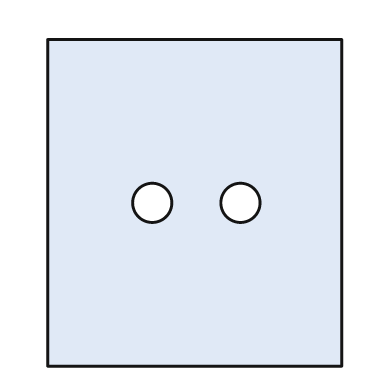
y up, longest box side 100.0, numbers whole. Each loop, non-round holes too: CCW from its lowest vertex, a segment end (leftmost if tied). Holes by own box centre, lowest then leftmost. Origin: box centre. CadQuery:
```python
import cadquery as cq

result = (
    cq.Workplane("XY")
    .moveTo(-45.0, -50.0)
    .lineTo(45.0, -50.0)
    .lineTo(45.0, 50.0)
    .lineTo(-45.0, 50.0)
    .close()
    .moveTo(-13.0, 0.0)
    .circle(6.0)
    .moveTo(14.0, 0.0)
    .circle(6.0)
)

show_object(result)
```